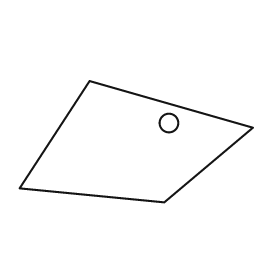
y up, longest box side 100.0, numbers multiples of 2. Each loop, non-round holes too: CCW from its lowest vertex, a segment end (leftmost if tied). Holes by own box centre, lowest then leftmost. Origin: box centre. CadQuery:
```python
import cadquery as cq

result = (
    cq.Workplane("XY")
    .moveTo(12.0, -26.0)
    .lineTo(50.0, 6.0)
    .lineTo(-20.0, 26.0)
    .lineTo(-50.0, -20.0)
    .close()
    .moveTo(14.0, 8.0)
    .circle(4.0)
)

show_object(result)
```